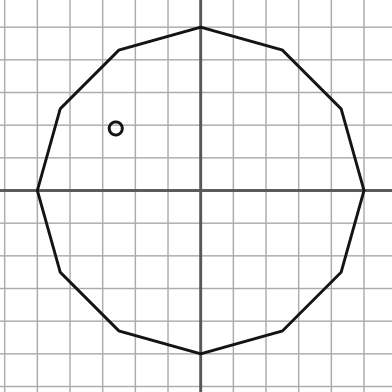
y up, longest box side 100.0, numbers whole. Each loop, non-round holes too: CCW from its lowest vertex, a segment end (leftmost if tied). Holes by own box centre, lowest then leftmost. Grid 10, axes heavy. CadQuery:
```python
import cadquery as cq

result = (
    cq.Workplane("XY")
    .moveTo(0.0, -50.0)
    .lineTo(25.0, -43.0)
    .lineTo(43.0, -25.0)
    .lineTo(50.0, 0.0)
    .lineTo(43.0, 25.0)
    .lineTo(25.0, 43.0)
    .lineTo(0.0, 50.0)
    .lineTo(-25.0, 43.0)
    .lineTo(-43.0, 25.0)
    .lineTo(-50.0, 0.0)
    .lineTo(-43.0, -25.0)
    .lineTo(-25.0, -43.0)
    .close()
    .moveTo(-26.0, 19.0)
    .circle(2.0)
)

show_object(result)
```